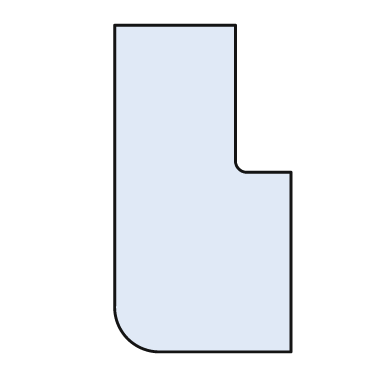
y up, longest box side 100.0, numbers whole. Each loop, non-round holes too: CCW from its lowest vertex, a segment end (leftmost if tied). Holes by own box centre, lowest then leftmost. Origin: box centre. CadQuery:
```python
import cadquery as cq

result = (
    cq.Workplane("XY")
    .moveTo(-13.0, -50.0)
    .lineTo(27.0, -50.0)
    .lineTo(27.0, 5.0)
    .lineTo(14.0, 5.0)
    .threePointArc((11.0, 6.0), (10.0, 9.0))
    .lineTo(10.0, 50.0)
    .lineTo(-27.0, 50.0)
    .lineTo(-27.0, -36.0)
    .threePointArc((-23.0, -46.0), (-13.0, -50.0))
    .close()
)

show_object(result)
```